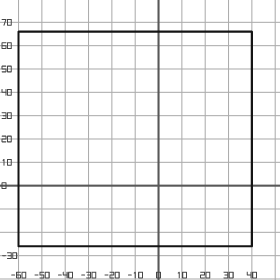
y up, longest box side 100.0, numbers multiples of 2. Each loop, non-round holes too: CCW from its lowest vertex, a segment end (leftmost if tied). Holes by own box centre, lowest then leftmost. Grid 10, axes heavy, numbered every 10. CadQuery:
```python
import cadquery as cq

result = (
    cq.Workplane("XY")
    .moveTo(-60.0, -26.0)
    .lineTo(40.0, -26.0)
    .lineTo(40.0, 66.0)
    .lineTo(-60.0, 66.0)
    .close()
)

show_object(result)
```